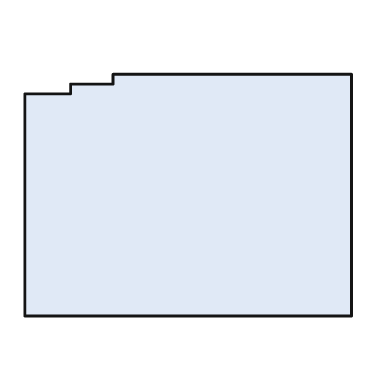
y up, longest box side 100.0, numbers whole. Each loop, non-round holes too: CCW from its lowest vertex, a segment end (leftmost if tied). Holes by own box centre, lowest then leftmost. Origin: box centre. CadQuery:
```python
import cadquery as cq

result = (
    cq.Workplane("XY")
    .moveTo(-50.0, -37.0)
    .lineTo(50.0, -37.0)
    .lineTo(50.0, 37.0)
    .lineTo(-23.0, 37.0)
    .lineTo(-23.0, 34.0)
    .lineTo(-36.0, 34.0)
    .lineTo(-36.0, 31.0)
    .lineTo(-50.0, 31.0)
    .close()
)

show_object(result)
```